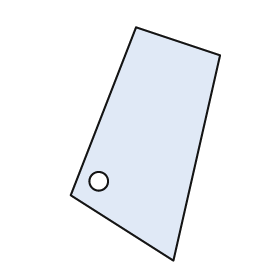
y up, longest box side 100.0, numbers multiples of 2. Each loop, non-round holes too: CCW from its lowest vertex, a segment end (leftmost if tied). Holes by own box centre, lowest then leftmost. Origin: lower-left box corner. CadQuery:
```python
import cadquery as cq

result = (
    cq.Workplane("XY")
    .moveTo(44.0, 0.0)
    .lineTo(64.0, 88.0)
    .lineTo(28.0, 100.0)
    .lineTo(0.0, 28.0)
    .close()
    .moveTo(12.0, 34.0)
    .circle(4.0)
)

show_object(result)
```